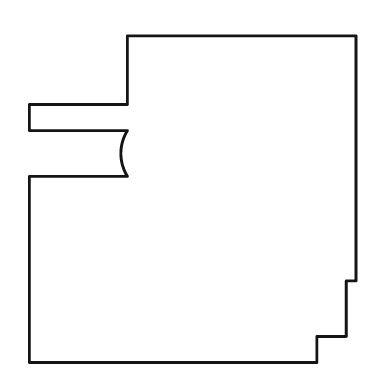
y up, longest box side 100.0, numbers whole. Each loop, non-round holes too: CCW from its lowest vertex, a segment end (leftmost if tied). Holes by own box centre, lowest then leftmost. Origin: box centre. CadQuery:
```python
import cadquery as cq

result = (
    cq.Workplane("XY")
    .moveTo(-50.0, -50.0)
    .lineTo(38.0, -50.0)
    .lineTo(38.0, -42.0)
    .lineTo(47.0, -42.0)
    .lineTo(47.0, -25.0)
    .lineTo(50.0, -25.0)
    .lineTo(50.0, 50.0)
    .lineTo(-20.0, 50.0)
    .lineTo(-20.0, 29.0)
    .lineTo(-50.0, 29.0)
    .lineTo(-50.0, 21.0)
    .lineTo(-20.0, 21.0)
    .threePointArc((-22.0, 14.0), (-20.0, 7.0))
    .lineTo(-50.0, 7.0)
    .close()
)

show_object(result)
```